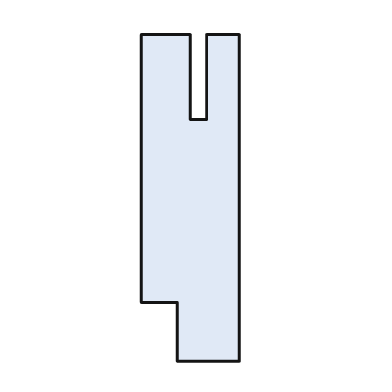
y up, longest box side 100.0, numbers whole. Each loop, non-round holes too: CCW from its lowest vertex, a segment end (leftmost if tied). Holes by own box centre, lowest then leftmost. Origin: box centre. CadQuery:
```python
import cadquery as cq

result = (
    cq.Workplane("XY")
    .moveTo(-4.0, -50.0)
    .lineTo(15.0, -50.0)
    .lineTo(15.0, 50.0)
    .lineTo(5.0, 50.0)
    .lineTo(5.0, 24.0)
    .lineTo(0.0, 24.0)
    .lineTo(0.0, 50.0)
    .lineTo(-15.0, 50.0)
    .lineTo(-15.0, -32.0)
    .lineTo(-4.0, -32.0)
    .close()
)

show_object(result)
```